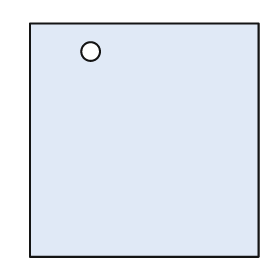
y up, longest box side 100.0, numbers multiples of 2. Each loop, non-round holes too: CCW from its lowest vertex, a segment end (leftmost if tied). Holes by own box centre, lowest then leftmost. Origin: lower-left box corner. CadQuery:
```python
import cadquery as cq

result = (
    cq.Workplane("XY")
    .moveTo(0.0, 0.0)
    .lineTo(98.0, 0.0)
    .lineTo(98.0, 100.0)
    .lineTo(0.0, 100.0)
    .close()
    .moveTo(26.0, 88.0)
    .circle(4.0)
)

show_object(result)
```